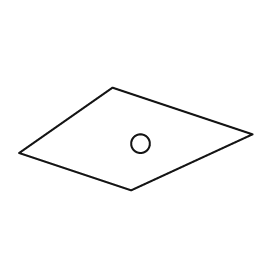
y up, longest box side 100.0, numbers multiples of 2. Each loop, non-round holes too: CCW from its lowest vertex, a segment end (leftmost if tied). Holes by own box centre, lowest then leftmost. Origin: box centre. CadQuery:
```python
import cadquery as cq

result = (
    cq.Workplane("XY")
    .moveTo(-2.0, -22.0)
    .lineTo(50.0, 2.0)
    .lineTo(-10.0, 22.0)
    .lineTo(-50.0, -6.0)
    .close()
    .moveTo(2.0, -2.0)
    .circle(4.0)
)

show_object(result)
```